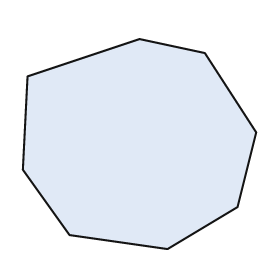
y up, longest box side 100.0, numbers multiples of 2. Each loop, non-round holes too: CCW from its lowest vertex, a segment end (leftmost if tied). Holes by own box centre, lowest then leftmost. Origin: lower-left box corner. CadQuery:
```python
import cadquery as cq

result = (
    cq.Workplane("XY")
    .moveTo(62.0, 0.0)
    .lineTo(92.0, 18.0)
    .lineTo(100.0, 50.0)
    .lineTo(78.0, 84.0)
    .lineTo(50.0, 90.0)
    .lineTo(2.0, 74.0)
    .lineTo(0.0, 34.0)
    .lineTo(20.0, 6.0)
    .close()
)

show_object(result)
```